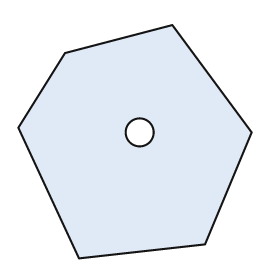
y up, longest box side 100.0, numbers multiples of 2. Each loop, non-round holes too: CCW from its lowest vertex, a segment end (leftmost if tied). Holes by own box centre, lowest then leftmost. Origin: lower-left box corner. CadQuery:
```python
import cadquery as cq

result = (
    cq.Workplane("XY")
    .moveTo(26.0, 0.0)
    .lineTo(80.0, 6.0)
    .lineTo(100.0, 54.0)
    .lineTo(66.0, 100.0)
    .lineTo(20.0, 88.0)
    .lineTo(0.0, 56.0)
    .close()
    .moveTo(52.0, 54.0)
    .circle(6.0)
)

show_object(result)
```